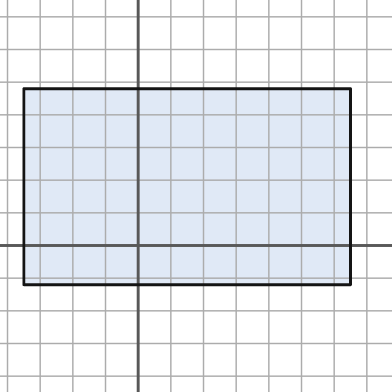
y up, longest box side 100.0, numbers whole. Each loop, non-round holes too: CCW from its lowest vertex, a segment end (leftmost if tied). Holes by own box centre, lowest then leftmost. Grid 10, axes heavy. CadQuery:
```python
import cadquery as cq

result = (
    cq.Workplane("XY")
    .moveTo(-35.0, -12.0)
    .lineTo(65.0, -12.0)
    .lineTo(65.0, 48.0)
    .lineTo(-35.0, 48.0)
    .close()
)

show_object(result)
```